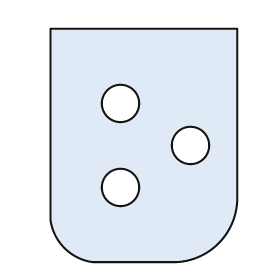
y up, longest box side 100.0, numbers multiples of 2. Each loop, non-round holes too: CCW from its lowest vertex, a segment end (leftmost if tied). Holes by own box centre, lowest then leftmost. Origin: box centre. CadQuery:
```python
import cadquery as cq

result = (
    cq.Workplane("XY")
    .moveTo(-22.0, -50.0)
    .lineTo(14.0, -50.0)
    .threePointArc((32.0, -42.0), (40.0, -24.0))
    .lineTo(40.0, 50.0)
    .lineTo(-40.0, 50.0)
    .lineTo(-40.0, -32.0)
    .threePointArc((-34.0, -44.0), (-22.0, -50.0))
    .close()
    .moveTo(-10.0, -18.0)
    .circle(8.0)
    .moveTo(20.0, 0.0)
    .circle(8.0)
    .moveTo(-10.0, 18.0)
    .circle(8.0)
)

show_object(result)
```